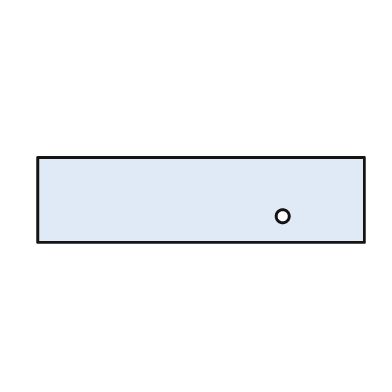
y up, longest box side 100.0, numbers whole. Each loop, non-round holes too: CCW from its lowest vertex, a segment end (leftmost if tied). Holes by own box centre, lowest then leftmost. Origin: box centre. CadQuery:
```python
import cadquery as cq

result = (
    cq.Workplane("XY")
    .moveTo(-50.0, -13.0)
    .lineTo(50.0, -13.0)
    .lineTo(50.0, 13.0)
    .lineTo(-50.0, 13.0)
    .close()
    .moveTo(25.0, -5.0)
    .circle(2.0)
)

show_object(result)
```